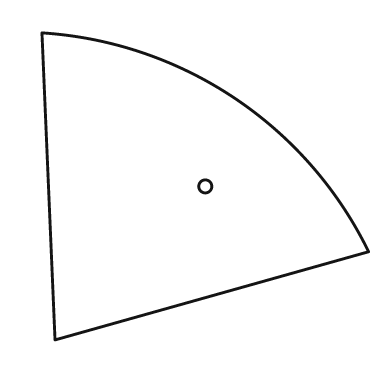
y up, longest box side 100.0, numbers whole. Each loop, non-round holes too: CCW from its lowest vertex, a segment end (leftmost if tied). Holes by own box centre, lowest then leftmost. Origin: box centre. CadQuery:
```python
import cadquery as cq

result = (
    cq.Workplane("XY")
    .moveTo(-46.0, -47.0)
    .lineTo(50.0, -20.0)
    .threePointArc((9.0, 27.0), (-50.0, 47.0))
    .close()
    .moveTo(0.0, 0.0)
    .circle(2.0)
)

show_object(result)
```